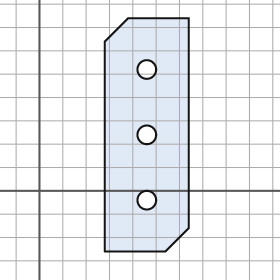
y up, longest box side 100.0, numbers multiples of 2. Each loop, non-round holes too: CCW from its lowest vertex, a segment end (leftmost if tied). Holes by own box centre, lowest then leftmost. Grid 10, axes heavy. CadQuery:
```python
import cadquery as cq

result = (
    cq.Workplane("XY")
    .moveTo(28.0, -26.0)
    .lineTo(54.0, -26.0)
    .lineTo(64.0, -16.0)
    .lineTo(64.0, 74.0)
    .lineTo(38.0, 74.0)
    .lineTo(28.0, 64.0)
    .close()
    .moveTo(46.0, -4.0)
    .circle(4.0)
    .moveTo(46.0, 24.0)
    .circle(4.0)
    .moveTo(46.0, 52.0)
    .circle(4.0)
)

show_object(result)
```